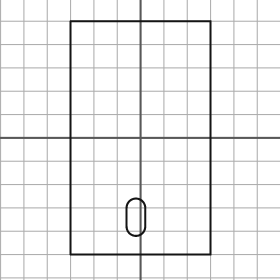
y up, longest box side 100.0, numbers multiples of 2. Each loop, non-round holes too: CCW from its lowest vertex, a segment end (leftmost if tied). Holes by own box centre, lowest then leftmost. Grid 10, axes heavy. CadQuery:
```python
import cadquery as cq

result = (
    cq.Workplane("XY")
    .moveTo(-30.0, -50.0)
    .lineTo(30.0, -50.0)
    .lineTo(30.0, 50.0)
    .lineTo(-30.0, 50.0)
    .close()
    .moveTo(-6.0, -38.0)
    .threePointArc((-2.0, -42.0), (2.0, -38.0))
    .lineTo(2.0, -30.0)
    .threePointArc((-2.0, -26.0), (-6.0, -30.0))
    .close()
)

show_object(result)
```